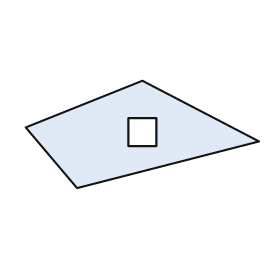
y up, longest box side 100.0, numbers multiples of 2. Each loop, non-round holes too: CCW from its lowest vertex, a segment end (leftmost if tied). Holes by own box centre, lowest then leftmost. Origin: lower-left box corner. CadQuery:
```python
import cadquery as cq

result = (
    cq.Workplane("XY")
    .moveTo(22.0, 0.0)
    .lineTo(100.0, 20.0)
    .lineTo(50.0, 46.0)
    .lineTo(0.0, 26.0)
    .close()
    .moveTo(44.0, 18.0)
    .lineTo(56.0, 18.0)
    .lineTo(56.0, 30.0)
    .lineTo(44.0, 30.0)
    .close()
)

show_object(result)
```